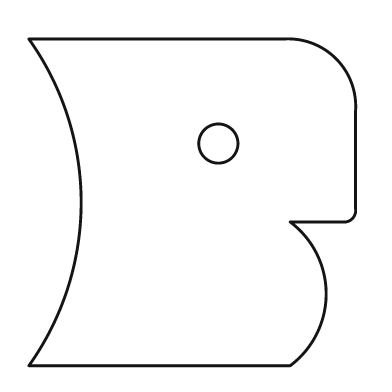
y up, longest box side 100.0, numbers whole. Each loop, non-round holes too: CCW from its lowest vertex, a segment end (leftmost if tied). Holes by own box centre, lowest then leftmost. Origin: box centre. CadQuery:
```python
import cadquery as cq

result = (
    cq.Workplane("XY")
    .moveTo(-50.0, -50.0)
    .lineTo(30.0, -50.0)
    .threePointArc((41.0, -28.0), (30.0, -6.0))
    .lineTo(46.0, -6.0)
    .threePointArc((49.0, -5.0), (50.0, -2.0))
    .lineTo(50.0, 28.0)
    .threePointArc((44.0, 44.0), (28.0, 50.0))
    .lineTo(-50.0, 50.0)
    .threePointArc((-34.0, 0.0), (-50.0, -50.0))
    .close()
    .moveTo(8.0, 18.0)
    .circle(6.0)
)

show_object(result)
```